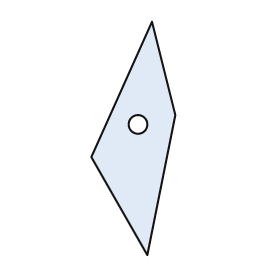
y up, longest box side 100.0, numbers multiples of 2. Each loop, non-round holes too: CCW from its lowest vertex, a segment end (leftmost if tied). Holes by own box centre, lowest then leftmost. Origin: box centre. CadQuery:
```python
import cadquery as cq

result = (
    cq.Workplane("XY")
    .moveTo(6.0, -50.0)
    .lineTo(18.0, 10.0)
    .lineTo(8.0, 50.0)
    .lineTo(-18.0, -8.0)
    .close()
    .moveTo(2.0, 6.0)
    .circle(4.0)
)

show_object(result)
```